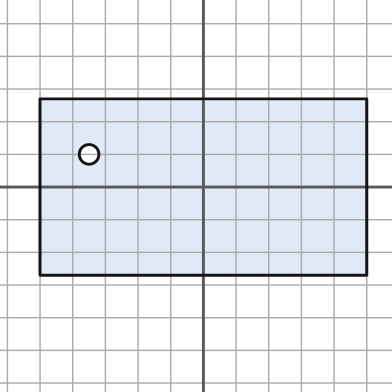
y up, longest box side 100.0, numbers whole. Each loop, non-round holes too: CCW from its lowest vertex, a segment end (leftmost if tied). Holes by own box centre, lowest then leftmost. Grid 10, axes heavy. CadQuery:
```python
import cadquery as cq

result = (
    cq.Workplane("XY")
    .moveTo(-50.0, -27.0)
    .lineTo(50.0, -27.0)
    .lineTo(50.0, 27.0)
    .lineTo(-50.0, 27.0)
    .close()
    .moveTo(-35.0, 10.0)
    .circle(3.0)
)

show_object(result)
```